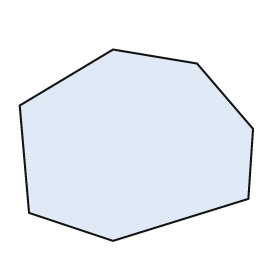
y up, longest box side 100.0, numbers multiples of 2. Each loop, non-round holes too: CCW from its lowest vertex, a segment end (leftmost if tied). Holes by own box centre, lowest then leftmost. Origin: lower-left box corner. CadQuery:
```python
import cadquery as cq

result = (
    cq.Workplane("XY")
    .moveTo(40.0, 0.0)
    .lineTo(98.0, 18.0)
    .lineTo(100.0, 48.0)
    .lineTo(76.0, 76.0)
    .lineTo(40.0, 82.0)
    .lineTo(0.0, 58.0)
    .lineTo(4.0, 12.0)
    .close()
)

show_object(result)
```